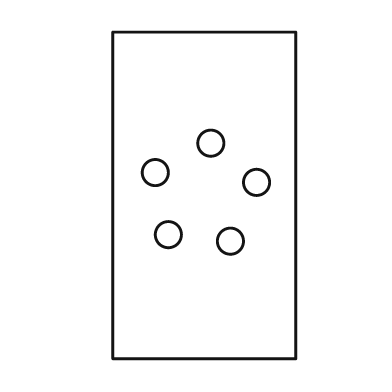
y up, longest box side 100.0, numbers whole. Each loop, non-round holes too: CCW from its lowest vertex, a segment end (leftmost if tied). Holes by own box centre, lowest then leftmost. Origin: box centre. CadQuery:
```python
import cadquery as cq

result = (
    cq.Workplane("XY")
    .moveTo(-28.0, -50.0)
    .lineTo(28.0, -50.0)
    .lineTo(28.0, 50.0)
    .lineTo(-28.0, 50.0)
    .close()
    .moveTo(8.0, -14.0)
    .circle(4.0)
    .moveTo(-11.0, -12.0)
    .circle(4.0)
    .moveTo(16.0, 4.0)
    .circle(4.0)
    .moveTo(-15.0, 7.0)
    .circle(4.0)
    .moveTo(2.0, 16.0)
    .circle(4.0)
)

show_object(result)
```